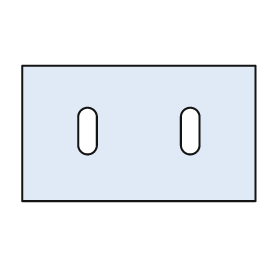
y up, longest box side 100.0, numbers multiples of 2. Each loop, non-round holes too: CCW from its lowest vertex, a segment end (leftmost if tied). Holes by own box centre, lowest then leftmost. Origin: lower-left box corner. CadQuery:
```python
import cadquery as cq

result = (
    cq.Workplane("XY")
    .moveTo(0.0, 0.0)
    .lineTo(100.0, 0.0)
    .lineTo(100.0, 58.0)
    .lineTo(0.0, 58.0)
    .close()
    .moveTo(24.0, 24.0)
    .threePointArc((28.0, 20.0), (32.0, 24.0))
    .lineTo(32.0, 36.0)
    .threePointArc((28.0, 40.0), (24.0, 36.0))
    .close()
    .moveTo(68.0, 24.0)
    .threePointArc((72.0, 20.0), (76.0, 24.0))
    .lineTo(76.0, 36.0)
    .threePointArc((72.0, 40.0), (68.0, 36.0))
    .close()
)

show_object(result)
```